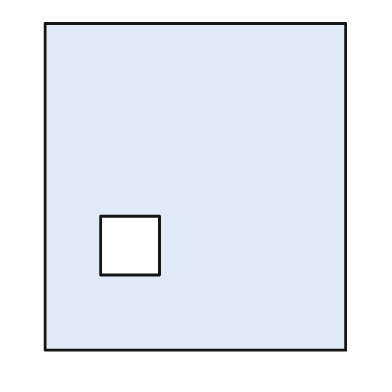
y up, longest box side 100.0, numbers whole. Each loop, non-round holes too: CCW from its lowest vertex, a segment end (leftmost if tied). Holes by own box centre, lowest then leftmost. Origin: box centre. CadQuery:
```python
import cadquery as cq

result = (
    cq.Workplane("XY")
    .moveTo(-46.0, -50.0)
    .lineTo(46.0, -50.0)
    .lineTo(46.0, 50.0)
    .lineTo(-46.0, 50.0)
    .close()
    .moveTo(-29.0, -27.0)
    .lineTo(-11.0, -27.0)
    .lineTo(-11.0, -9.0)
    .lineTo(-29.0, -9.0)
    .close()
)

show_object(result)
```